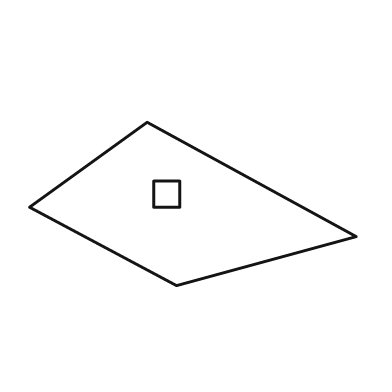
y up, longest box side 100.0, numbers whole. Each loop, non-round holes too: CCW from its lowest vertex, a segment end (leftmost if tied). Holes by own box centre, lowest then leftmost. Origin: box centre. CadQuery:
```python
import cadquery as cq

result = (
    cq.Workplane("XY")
    .moveTo(-5.0, -25.0)
    .lineTo(50.0, -10.0)
    .lineTo(-14.0, 25.0)
    .lineTo(-50.0, -1.0)
    .close()
    .moveTo(-12.0, -1.0)
    .lineTo(-4.0, -1.0)
    .lineTo(-4.0, 7.0)
    .lineTo(-12.0, 7.0)
    .close()
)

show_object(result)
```